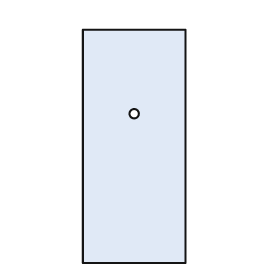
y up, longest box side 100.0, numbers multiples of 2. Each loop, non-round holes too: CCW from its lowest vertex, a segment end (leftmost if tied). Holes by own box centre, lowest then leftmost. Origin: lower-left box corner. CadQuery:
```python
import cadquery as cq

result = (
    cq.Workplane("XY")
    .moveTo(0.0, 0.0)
    .lineTo(44.0, 0.0)
    .lineTo(44.0, 100.0)
    .lineTo(0.0, 100.0)
    .close()
    .moveTo(22.0, 64.0)
    .circle(2.0)
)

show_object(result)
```